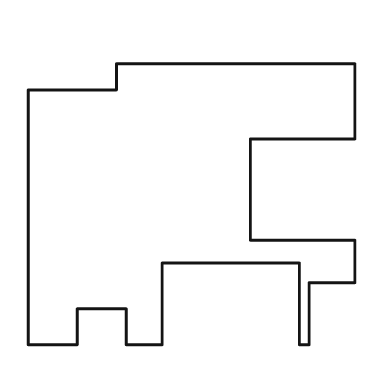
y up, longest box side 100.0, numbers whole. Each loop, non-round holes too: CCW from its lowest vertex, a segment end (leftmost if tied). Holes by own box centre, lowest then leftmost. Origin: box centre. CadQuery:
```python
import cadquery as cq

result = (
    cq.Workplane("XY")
    .moveTo(-50.0, -43.0)
    .lineTo(-35.0, -43.0)
    .lineTo(-35.0, -32.0)
    .lineTo(-20.0, -32.0)
    .lineTo(-20.0, -43.0)
    .lineTo(-9.0, -43.0)
    .lineTo(-9.0, -18.0)
    .lineTo(33.0, -18.0)
    .lineTo(33.0, -43.0)
    .lineTo(36.0, -43.0)
    .lineTo(36.0, -24.0)
    .lineTo(50.0, -24.0)
    .lineTo(50.0, -11.0)
    .lineTo(18.0, -11.0)
    .lineTo(18.0, 20.0)
    .lineTo(50.0, 20.0)
    .lineTo(50.0, 43.0)
    .lineTo(-23.0, 43.0)
    .lineTo(-23.0, 35.0)
    .lineTo(-50.0, 35.0)
    .close()
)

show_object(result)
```